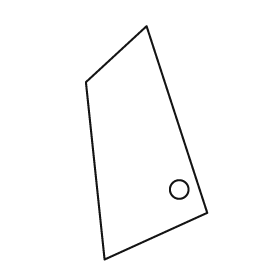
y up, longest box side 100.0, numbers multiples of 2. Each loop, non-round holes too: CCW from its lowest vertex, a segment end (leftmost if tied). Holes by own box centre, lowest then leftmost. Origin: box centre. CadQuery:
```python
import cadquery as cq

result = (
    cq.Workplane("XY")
    .moveTo(-18.0, -50.0)
    .lineTo(26.0, -30.0)
    .lineTo(0.0, 50.0)
    .lineTo(-26.0, 26.0)
    .close()
    .moveTo(14.0, -20.0)
    .circle(4.0)
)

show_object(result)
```